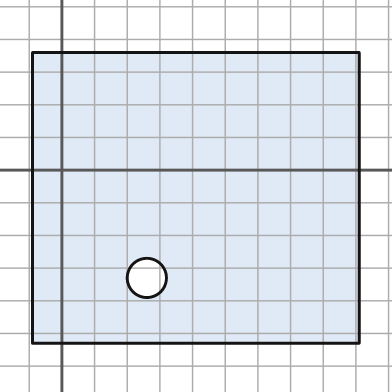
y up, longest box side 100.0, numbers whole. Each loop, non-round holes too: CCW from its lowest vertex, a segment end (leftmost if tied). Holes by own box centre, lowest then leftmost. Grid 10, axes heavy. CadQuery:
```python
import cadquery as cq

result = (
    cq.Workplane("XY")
    .moveTo(-9.0, -53.0)
    .lineTo(91.0, -53.0)
    .lineTo(91.0, 36.0)
    .lineTo(-9.0, 36.0)
    .close()
    .moveTo(26.0, -33.0)
    .circle(6.0)
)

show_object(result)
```